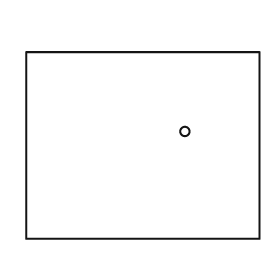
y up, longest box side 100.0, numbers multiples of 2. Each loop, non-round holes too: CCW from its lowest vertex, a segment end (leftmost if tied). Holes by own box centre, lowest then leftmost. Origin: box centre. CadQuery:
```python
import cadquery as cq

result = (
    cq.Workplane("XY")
    .moveTo(-50.0, -40.0)
    .lineTo(50.0, -40.0)
    .lineTo(50.0, 40.0)
    .lineTo(-50.0, 40.0)
    .close()
    .moveTo(18.0, 6.0)
    .circle(2.0)
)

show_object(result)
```